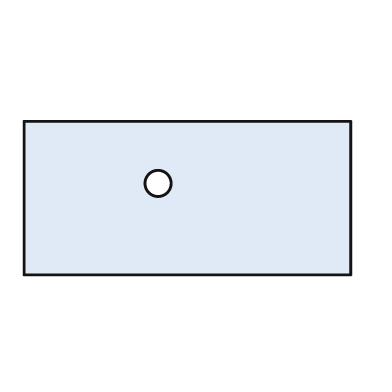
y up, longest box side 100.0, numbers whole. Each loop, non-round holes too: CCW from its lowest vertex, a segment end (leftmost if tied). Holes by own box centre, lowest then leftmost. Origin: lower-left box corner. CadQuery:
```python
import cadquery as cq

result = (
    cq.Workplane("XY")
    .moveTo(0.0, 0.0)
    .lineTo(100.0, 0.0)
    .lineTo(100.0, 47.0)
    .lineTo(0.0, 47.0)
    .close()
    .moveTo(41.0, 28.0)
    .circle(4.0)
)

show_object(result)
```